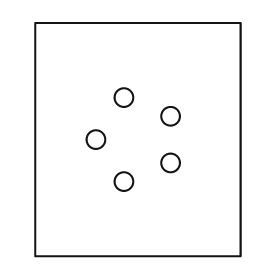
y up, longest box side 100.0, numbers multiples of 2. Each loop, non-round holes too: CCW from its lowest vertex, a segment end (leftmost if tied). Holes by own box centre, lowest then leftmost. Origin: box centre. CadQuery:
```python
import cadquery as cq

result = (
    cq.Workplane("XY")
    .moveTo(-44.0, -50.0)
    .lineTo(44.0, -50.0)
    .lineTo(44.0, 50.0)
    .lineTo(-44.0, 50.0)
    .close()
    .moveTo(-6.0, -18.0)
    .circle(4.0)
    .moveTo(14.0, -10.0)
    .circle(4.0)
    .moveTo(-18.0, 0.0)
    .circle(4.0)
    .moveTo(14.0, 10.0)
    .circle(4.0)
    .moveTo(-6.0, 18.0)
    .circle(4.0)
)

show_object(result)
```